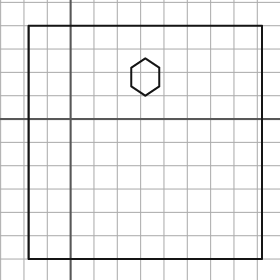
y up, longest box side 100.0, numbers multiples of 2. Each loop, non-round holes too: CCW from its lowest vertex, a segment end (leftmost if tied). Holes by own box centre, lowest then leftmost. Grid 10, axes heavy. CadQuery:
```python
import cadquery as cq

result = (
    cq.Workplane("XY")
    .moveTo(-18.0, -60.0)
    .lineTo(82.0, -60.0)
    .lineTo(82.0, 40.0)
    .lineTo(-18.0, 40.0)
    .close()
    .moveTo(32.0, 10.0)
    .lineTo(38.0, 14.0)
    .lineTo(38.0, 22.0)
    .lineTo(32.0, 26.0)
    .lineTo(26.0, 22.0)
    .lineTo(26.0, 14.0)
    .close()
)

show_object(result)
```